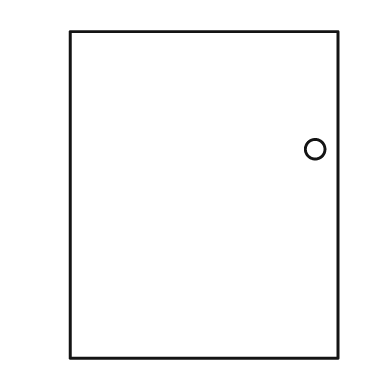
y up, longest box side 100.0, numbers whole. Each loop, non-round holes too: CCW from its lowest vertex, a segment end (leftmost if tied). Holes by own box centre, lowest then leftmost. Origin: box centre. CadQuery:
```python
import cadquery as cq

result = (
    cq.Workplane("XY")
    .moveTo(-41.0, -50.0)
    .lineTo(41.0, -50.0)
    .lineTo(41.0, 50.0)
    .lineTo(-41.0, 50.0)
    .close()
    .moveTo(34.0, 14.0)
    .circle(3.0)
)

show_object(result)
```